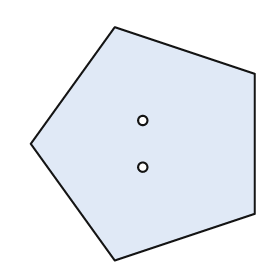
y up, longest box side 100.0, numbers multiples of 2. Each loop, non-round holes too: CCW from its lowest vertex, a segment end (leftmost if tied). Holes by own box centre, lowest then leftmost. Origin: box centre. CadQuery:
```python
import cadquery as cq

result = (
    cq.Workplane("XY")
    .moveTo(-12.0, -50.0)
    .lineTo(48.0, -30.0)
    .lineTo(48.0, 30.0)
    .lineTo(-12.0, 50.0)
    .lineTo(-48.0, 0.0)
    .close()
    .moveTo(0.0, -10.0)
    .circle(2.0)
    .moveTo(0.0, 10.0)
    .circle(2.0)
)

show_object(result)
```